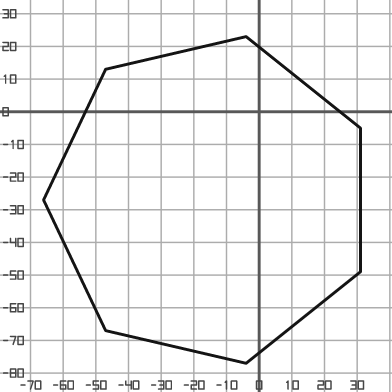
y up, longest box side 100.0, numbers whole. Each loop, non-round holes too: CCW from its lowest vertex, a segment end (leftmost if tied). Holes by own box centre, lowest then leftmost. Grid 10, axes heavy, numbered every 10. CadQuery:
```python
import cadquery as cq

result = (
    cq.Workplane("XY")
    .moveTo(-4.0, -77.0)
    .lineTo(31.0, -49.0)
    .lineTo(31.0, -5.0)
    .lineTo(-4.0, 23.0)
    .lineTo(-47.0, 13.0)
    .lineTo(-66.0, -27.0)
    .lineTo(-47.0, -67.0)
    .close()
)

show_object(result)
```